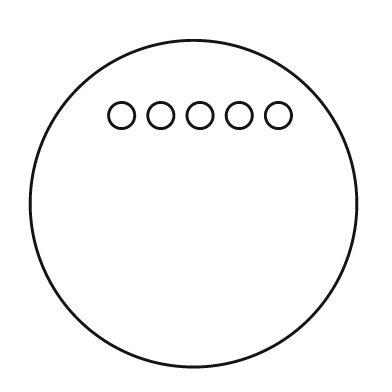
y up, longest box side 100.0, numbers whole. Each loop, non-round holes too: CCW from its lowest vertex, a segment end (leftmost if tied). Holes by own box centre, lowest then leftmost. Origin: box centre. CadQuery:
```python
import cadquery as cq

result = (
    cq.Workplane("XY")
    .moveTo(0.0, 0.0)
    .circle(50.0)
    .moveTo(-22.0, 27.0)
    .circle(4.0)
    .moveTo(-10.0, 27.0)
    .circle(4.0)
    .moveTo(2.0, 27.0)
    .circle(4.0)
    .moveTo(14.0, 27.0)
    .circle(4.0)
    .moveTo(26.0, 27.0)
    .circle(4.0)
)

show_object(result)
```